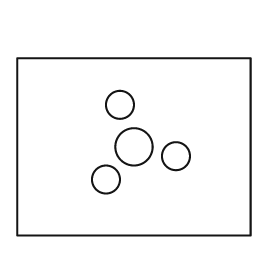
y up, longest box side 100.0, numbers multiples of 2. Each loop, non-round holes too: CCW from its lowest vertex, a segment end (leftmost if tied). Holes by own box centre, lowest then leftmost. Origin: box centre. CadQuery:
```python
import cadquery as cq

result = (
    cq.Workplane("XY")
    .moveTo(-50.0, -38.0)
    .lineTo(50.0, -38.0)
    .lineTo(50.0, 38.0)
    .lineTo(-50.0, 38.0)
    .close()
    .moveTo(-12.0, -14.0)
    .circle(6.0)
    .moveTo(18.0, -4.0)
    .circle(6.0)
    .moveTo(0.0, 0.0)
    .circle(8.0)
    .moveTo(-6.0, 18.0)
    .circle(6.0)
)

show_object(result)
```